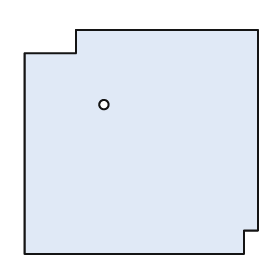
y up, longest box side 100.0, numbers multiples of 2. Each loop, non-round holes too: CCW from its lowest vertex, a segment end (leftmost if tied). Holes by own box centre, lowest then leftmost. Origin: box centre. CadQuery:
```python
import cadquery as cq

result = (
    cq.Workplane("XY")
    .moveTo(-50.0, -48.0)
    .lineTo(44.0, -48.0)
    .lineTo(44.0, -38.0)
    .lineTo(50.0, -38.0)
    .lineTo(50.0, 48.0)
    .lineTo(-28.0, 48.0)
    .lineTo(-28.0, 38.0)
    .lineTo(-50.0, 38.0)
    .close()
    .moveTo(-16.0, 16.0)
    .circle(2.0)
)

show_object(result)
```